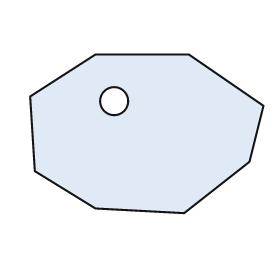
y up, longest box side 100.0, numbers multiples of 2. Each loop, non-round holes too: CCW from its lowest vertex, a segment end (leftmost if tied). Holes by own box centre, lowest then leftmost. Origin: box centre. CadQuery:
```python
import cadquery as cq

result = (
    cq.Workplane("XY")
    .moveTo(16.0, -34.0)
    .lineTo(44.0, -12.0)
    .lineTo(50.0, 12.0)
    .lineTo(18.0, 34.0)
    .lineTo(-22.0, 34.0)
    .lineTo(-50.0, 16.0)
    .lineTo(-48.0, -16.0)
    .lineTo(-22.0, -32.0)
    .close()
    .moveTo(-14.0, 14.0)
    .circle(6.0)
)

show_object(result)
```